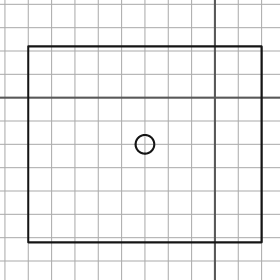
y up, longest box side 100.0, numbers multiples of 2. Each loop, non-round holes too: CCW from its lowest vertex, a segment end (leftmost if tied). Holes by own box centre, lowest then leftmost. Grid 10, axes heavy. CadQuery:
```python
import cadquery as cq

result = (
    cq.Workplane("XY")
    .moveTo(-80.0, -62.0)
    .lineTo(20.0, -62.0)
    .lineTo(20.0, 22.0)
    .lineTo(-80.0, 22.0)
    .close()
    .moveTo(-30.0, -20.0)
    .circle(4.0)
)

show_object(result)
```